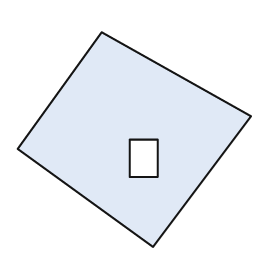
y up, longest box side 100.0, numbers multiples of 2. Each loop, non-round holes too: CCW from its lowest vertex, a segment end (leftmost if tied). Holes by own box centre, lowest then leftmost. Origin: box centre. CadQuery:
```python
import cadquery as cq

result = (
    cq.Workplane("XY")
    .moveTo(8.0, -46.0)
    .lineTo(50.0, 10.0)
    .lineTo(-14.0, 46.0)
    .lineTo(-50.0, -4.0)
    .close()
    .moveTo(-2.0, -16.0)
    .lineTo(10.0, -16.0)
    .lineTo(10.0, 0.0)
    .lineTo(-2.0, 0.0)
    .close()
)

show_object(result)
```